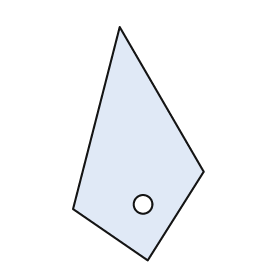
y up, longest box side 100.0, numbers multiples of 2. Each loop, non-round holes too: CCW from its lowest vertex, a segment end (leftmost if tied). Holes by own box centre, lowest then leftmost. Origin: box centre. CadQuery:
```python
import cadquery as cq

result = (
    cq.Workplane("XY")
    .moveTo(4.0, -50.0)
    .lineTo(28.0, -12.0)
    .lineTo(-8.0, 50.0)
    .lineTo(-28.0, -28.0)
    .close()
    .moveTo(2.0, -26.0)
    .circle(4.0)
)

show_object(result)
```